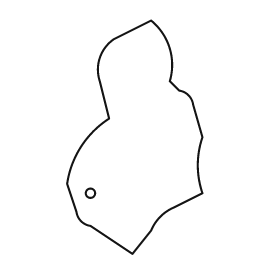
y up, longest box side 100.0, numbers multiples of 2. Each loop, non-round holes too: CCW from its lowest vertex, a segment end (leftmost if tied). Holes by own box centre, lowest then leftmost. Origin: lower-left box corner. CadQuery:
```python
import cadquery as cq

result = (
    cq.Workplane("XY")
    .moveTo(28.0, 0.0)
    .lineTo(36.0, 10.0)
    .threePointArc((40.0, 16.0), (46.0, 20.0))
    .lineTo(58.0, 26.0)
    .threePointArc((56.0, 38.0), (58.0, 50.0))
    .lineTo(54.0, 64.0)
    .threePointArc((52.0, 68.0), (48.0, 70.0))
    .lineTo(44.0, 74.0)
    .threePointArc((44.0, 88.0), (36.0, 100.0))
    .lineTo(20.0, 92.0)
    .threePointArc((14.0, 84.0), (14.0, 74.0))
    .lineTo(18.0, 58.0)
    .threePointArc((6.0, 46.0), (0.0, 30.0))
    .lineTo(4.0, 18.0)
    .threePointArc((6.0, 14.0), (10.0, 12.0))
    .close()
    .moveTo(10.0, 26.0)
    .circle(2.0)
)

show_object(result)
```